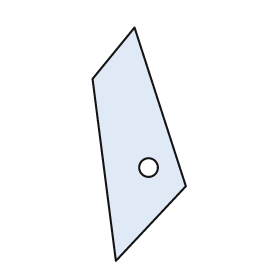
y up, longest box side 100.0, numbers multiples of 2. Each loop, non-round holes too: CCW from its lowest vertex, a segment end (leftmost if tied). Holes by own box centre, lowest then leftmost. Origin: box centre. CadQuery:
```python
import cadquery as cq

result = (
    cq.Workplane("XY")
    .moveTo(-10.0, -50.0)
    .lineTo(20.0, -18.0)
    .lineTo(-2.0, 50.0)
    .lineTo(-20.0, 28.0)
    .close()
    .moveTo(4.0, -10.0)
    .circle(4.0)
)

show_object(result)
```